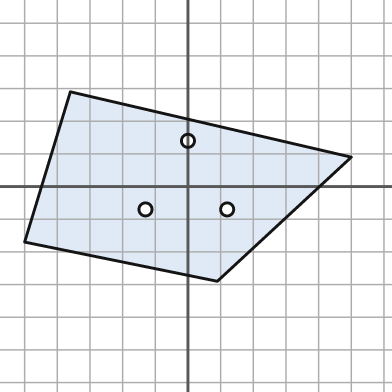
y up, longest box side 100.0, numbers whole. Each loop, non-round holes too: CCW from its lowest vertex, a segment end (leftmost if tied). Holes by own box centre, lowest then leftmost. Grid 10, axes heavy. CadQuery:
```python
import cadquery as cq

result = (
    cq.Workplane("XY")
    .moveTo(9.0, -29.0)
    .lineTo(50.0, 9.0)
    .lineTo(-36.0, 29.0)
    .lineTo(-50.0, -17.0)
    .close()
    .moveTo(-13.0, -7.0)
    .circle(2.0)
    .moveTo(12.0, -7.0)
    .circle(2.0)
    .moveTo(0.0, 14.0)
    .circle(2.0)
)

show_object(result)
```